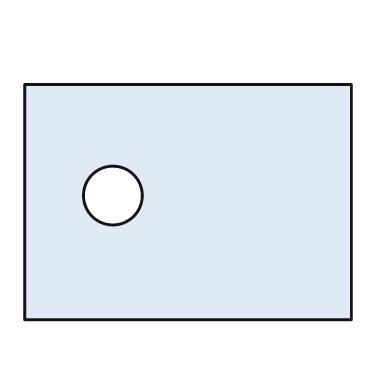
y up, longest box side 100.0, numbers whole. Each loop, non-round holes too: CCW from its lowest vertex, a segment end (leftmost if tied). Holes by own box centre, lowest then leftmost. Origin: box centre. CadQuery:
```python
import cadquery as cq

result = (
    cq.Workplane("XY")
    .moveTo(-50.0, -36.0)
    .lineTo(50.0, -36.0)
    .lineTo(50.0, 36.0)
    .lineTo(-50.0, 36.0)
    .close()
    .moveTo(-23.0, 2.0)
    .circle(9.0)
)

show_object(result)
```